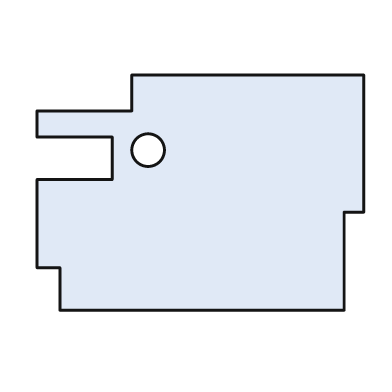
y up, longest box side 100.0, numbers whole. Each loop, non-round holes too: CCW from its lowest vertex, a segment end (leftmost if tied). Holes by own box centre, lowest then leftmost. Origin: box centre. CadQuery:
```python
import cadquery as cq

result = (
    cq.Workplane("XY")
    .moveTo(-43.0, -36.0)
    .lineTo(44.0, -36.0)
    .lineTo(44.0, -6.0)
    .lineTo(50.0, -6.0)
    .lineTo(50.0, 36.0)
    .lineTo(-21.0, 36.0)
    .lineTo(-21.0, 25.0)
    .lineTo(-50.0, 25.0)
    .lineTo(-50.0, 17.0)
    .lineTo(-27.0, 17.0)
    .lineTo(-27.0, 4.0)
    .lineTo(-50.0, 4.0)
    .lineTo(-50.0, -23.0)
    .lineTo(-43.0, -23.0)
    .close()
    .moveTo(-16.0, 13.0)
    .circle(5.0)
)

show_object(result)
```